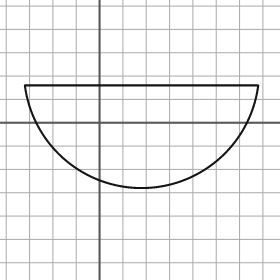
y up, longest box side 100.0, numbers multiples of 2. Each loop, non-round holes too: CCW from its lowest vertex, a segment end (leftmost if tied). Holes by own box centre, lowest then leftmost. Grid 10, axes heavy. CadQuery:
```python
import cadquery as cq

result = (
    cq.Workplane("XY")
    .moveTo(-32.0, 16.0)
    .threePointArc((18.0, -28.0), (68.0, 16.0))
    .close()
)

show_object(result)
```